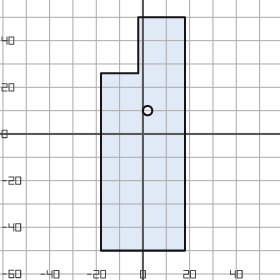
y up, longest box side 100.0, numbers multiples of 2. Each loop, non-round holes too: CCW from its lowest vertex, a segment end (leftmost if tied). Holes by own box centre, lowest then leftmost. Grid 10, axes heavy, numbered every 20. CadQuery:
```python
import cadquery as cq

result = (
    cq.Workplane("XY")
    .moveTo(-18.0, -50.0)
    .lineTo(18.0, -50.0)
    .lineTo(18.0, 50.0)
    .lineTo(-2.0, 50.0)
    .lineTo(-2.0, 26.0)
    .lineTo(-18.0, 26.0)
    .close()
    .moveTo(2.0, 10.0)
    .circle(2.0)
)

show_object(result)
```